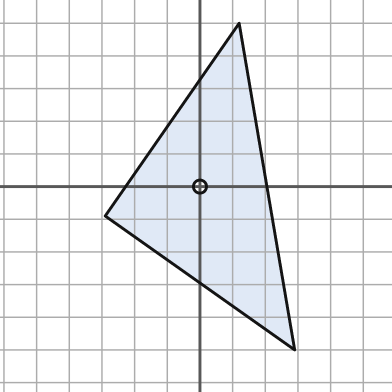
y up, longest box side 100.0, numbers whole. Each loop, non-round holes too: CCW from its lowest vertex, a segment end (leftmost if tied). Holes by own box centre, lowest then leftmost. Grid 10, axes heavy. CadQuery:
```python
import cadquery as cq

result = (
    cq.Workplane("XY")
    .moveTo(29.0, -50.0)
    .lineTo(12.0, 50.0)
    .lineTo(-29.0, -9.0)
    .close()
    .moveTo(0.0, 0.0)
    .circle(2.0)
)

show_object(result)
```